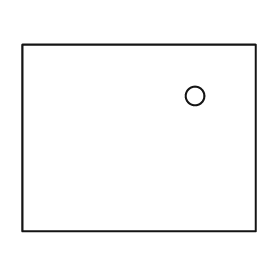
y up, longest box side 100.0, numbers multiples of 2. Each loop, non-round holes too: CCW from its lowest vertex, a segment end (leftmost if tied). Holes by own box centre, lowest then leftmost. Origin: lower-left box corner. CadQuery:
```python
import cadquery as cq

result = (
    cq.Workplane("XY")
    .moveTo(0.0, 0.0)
    .lineTo(100.0, 0.0)
    .lineTo(100.0, 80.0)
    .lineTo(0.0, 80.0)
    .close()
    .moveTo(74.0, 58.0)
    .circle(4.0)
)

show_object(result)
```